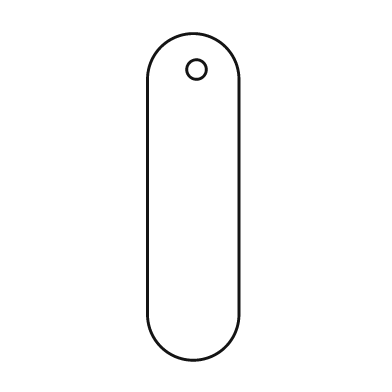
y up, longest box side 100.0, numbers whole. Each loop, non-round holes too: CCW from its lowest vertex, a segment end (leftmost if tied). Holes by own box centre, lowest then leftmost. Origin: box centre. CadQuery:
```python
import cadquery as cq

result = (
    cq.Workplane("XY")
    .moveTo(-14.0, -36.0)
    .threePointArc((0.0, -50.0), (14.0, -36.0))
    .lineTo(14.0, 36.0)
    .threePointArc((0.0, 50.0), (-14.0, 36.0))
    .close()
    .moveTo(1.0, 39.0)
    .circle(3.0)
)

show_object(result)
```